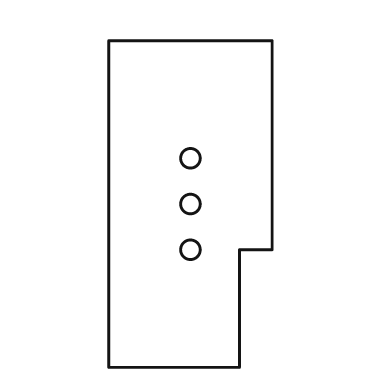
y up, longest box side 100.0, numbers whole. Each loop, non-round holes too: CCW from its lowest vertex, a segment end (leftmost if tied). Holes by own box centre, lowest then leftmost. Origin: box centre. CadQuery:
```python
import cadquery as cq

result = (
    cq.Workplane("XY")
    .moveTo(-25.0, -50.0)
    .lineTo(15.0, -50.0)
    .lineTo(15.0, -14.0)
    .lineTo(25.0, -14.0)
    .lineTo(25.0, 50.0)
    .lineTo(-25.0, 50.0)
    .close()
    .moveTo(0.0, -14.0)
    .circle(3.0)
    .moveTo(0.0, 0.0)
    .circle(3.0)
    .moveTo(0.0, 14.0)
    .circle(3.0)
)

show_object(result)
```